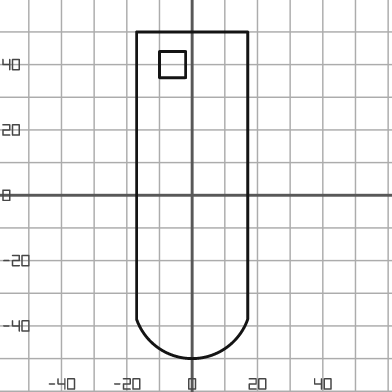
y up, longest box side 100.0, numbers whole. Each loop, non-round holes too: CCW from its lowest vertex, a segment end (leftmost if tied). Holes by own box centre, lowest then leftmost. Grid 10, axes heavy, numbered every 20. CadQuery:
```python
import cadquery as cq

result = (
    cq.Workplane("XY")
    .moveTo(-17.0, -38.0)
    .threePointArc((0.0, -50.0), (17.0, -38.0))
    .lineTo(17.0, 50.0)
    .lineTo(-17.0, 50.0)
    .close()
    .moveTo(-10.0, 36.0)
    .lineTo(-2.0, 36.0)
    .lineTo(-2.0, 44.0)
    .lineTo(-10.0, 44.0)
    .close()
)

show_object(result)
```